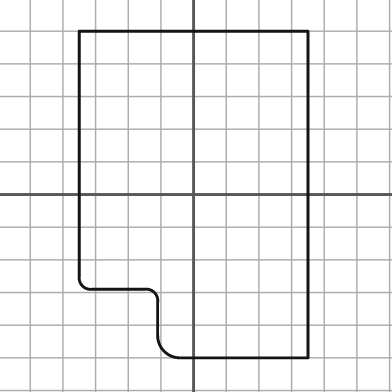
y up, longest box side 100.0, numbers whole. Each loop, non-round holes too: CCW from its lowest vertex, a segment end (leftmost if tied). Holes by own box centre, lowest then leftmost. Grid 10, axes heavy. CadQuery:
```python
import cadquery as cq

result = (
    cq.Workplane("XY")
    .moveTo(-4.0, -50.0)
    .lineTo(35.0, -50.0)
    .lineTo(35.0, 50.0)
    .lineTo(-35.0, 50.0)
    .lineTo(-35.0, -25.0)
    .threePointArc((-34.0, -28.0), (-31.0, -29.0))
    .lineTo(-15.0, -29.0)
    .threePointArc((-12.0, -30.0), (-11.0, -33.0))
    .lineTo(-11.0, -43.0)
    .threePointArc((-9.0, -48.0), (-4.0, -50.0))
    .close()
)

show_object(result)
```